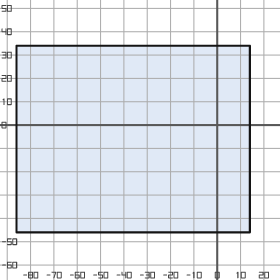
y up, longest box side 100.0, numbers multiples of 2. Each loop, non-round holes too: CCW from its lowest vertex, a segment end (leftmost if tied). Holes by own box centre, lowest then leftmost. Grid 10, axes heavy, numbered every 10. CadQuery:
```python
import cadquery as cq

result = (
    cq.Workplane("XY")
    .moveTo(-86.0, -46.0)
    .lineTo(14.0, -46.0)
    .lineTo(14.0, 34.0)
    .lineTo(-86.0, 34.0)
    .close()
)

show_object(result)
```